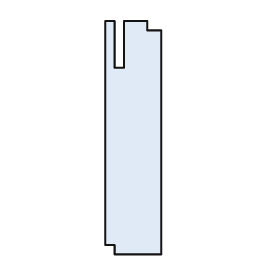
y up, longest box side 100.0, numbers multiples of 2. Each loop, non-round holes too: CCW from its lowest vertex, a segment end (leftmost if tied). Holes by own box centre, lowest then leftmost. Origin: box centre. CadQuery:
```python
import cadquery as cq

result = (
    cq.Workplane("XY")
    .moveTo(-8.0, -50.0)
    .lineTo(12.0, -50.0)
    .lineTo(12.0, 46.0)
    .lineTo(6.0, 46.0)
    .lineTo(6.0, 50.0)
    .lineTo(-4.0, 50.0)
    .lineTo(-4.0, 30.0)
    .lineTo(-8.0, 30.0)
    .lineTo(-8.0, 50.0)
    .lineTo(-12.0, 50.0)
    .lineTo(-12.0, -46.0)
    .lineTo(-8.0, -46.0)
    .close()
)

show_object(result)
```